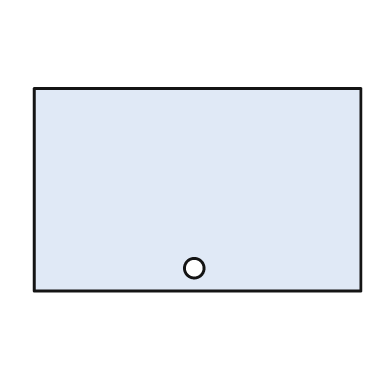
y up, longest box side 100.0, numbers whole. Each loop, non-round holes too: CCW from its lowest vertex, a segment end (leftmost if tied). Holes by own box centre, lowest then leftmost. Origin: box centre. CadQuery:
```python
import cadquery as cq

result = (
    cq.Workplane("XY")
    .moveTo(-50.0, -31.0)
    .lineTo(50.0, -31.0)
    .lineTo(50.0, 31.0)
    .lineTo(-50.0, 31.0)
    .close()
    .moveTo(-1.0, -24.0)
    .circle(3.0)
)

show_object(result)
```